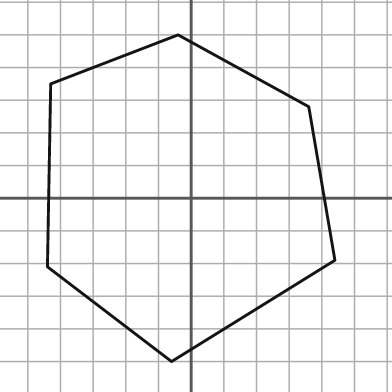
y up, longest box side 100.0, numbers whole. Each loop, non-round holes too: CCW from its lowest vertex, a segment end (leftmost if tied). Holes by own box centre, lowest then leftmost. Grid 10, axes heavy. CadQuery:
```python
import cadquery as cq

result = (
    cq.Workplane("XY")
    .moveTo(-6.0, -50.0)
    .lineTo(44.0, -19.0)
    .lineTo(36.0, 28.0)
    .lineTo(-4.0, 50.0)
    .lineTo(-43.0, 35.0)
    .lineTo(-44.0, -21.0)
    .close()
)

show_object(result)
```